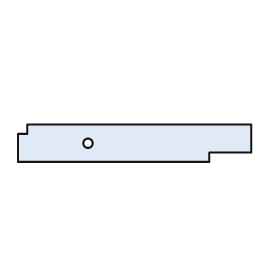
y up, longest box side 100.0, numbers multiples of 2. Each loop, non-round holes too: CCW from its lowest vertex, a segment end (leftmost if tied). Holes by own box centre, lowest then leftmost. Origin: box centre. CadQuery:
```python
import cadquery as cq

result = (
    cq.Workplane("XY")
    .moveTo(-50.0, -8.0)
    .lineTo(32.0, -8.0)
    .lineTo(32.0, -4.0)
    .lineTo(50.0, -4.0)
    .lineTo(50.0, 8.0)
    .lineTo(-46.0, 8.0)
    .lineTo(-46.0, 4.0)
    .lineTo(-50.0, 4.0)
    .close()
    .moveTo(-20.0, 0.0)
    .circle(2.0)
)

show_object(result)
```